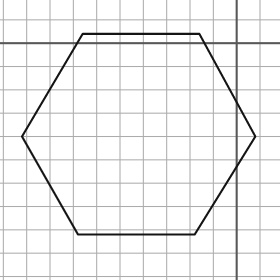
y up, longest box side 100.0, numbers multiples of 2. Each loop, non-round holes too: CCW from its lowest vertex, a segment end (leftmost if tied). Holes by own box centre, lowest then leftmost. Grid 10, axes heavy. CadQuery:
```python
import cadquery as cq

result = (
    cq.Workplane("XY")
    .moveTo(-68.0, -82.0)
    .lineTo(-18.0, -82.0)
    .lineTo(8.0, -40.0)
    .lineTo(-16.0, 4.0)
    .lineTo(-66.0, 4.0)
    .lineTo(-92.0, -40.0)
    .close()
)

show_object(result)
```